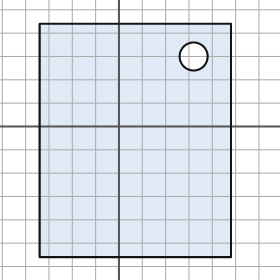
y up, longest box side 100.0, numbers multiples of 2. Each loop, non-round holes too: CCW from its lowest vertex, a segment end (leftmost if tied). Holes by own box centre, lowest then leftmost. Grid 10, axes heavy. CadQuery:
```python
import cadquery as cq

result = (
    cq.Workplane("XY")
    .moveTo(-34.0, -56.0)
    .lineTo(48.0, -56.0)
    .lineTo(48.0, 44.0)
    .lineTo(-34.0, 44.0)
    .close()
    .moveTo(32.0, 30.0)
    .circle(6.0)
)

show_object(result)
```